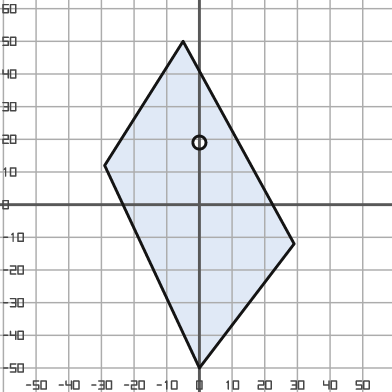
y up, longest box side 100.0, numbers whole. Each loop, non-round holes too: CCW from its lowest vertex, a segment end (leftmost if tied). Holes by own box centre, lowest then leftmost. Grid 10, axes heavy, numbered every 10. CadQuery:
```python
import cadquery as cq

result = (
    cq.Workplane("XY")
    .moveTo(0.0, -50.0)
    .lineTo(29.0, -12.0)
    .lineTo(-5.0, 50.0)
    .lineTo(-29.0, 12.0)
    .close()
    .moveTo(0.0, 19.0)
    .circle(2.0)
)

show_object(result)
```